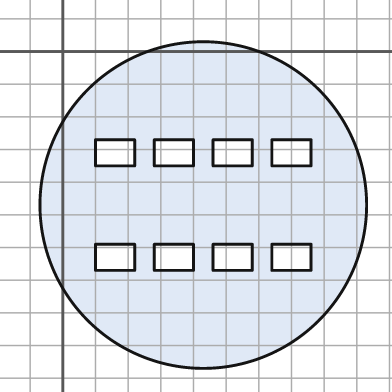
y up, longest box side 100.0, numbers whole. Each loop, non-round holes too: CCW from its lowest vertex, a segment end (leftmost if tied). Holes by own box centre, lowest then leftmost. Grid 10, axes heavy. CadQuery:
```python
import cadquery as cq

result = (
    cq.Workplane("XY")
    .moveTo(43.0, -47.0)
    .circle(50.0)
    .moveTo(10.0, -67.0)
    .lineTo(22.0, -67.0)
    .lineTo(22.0, -59.0)
    .lineTo(10.0, -59.0)
    .close()
    .moveTo(28.0, -67.0)
    .lineTo(40.0, -67.0)
    .lineTo(40.0, -59.0)
    .lineTo(28.0, -59.0)
    .close()
    .moveTo(46.0, -67.0)
    .lineTo(58.0, -67.0)
    .lineTo(58.0, -59.0)
    .lineTo(46.0, -59.0)
    .close()
    .moveTo(64.0, -67.0)
    .lineTo(76.0, -67.0)
    .lineTo(76.0, -59.0)
    .lineTo(64.0, -59.0)
    .close()
    .moveTo(10.0, -35.0)
    .lineTo(22.0, -35.0)
    .lineTo(22.0, -27.0)
    .lineTo(10.0, -27.0)
    .close()
    .moveTo(28.0, -35.0)
    .lineTo(40.0, -35.0)
    .lineTo(40.0, -27.0)
    .lineTo(28.0, -27.0)
    .close()
    .moveTo(46.0, -35.0)
    .lineTo(58.0, -35.0)
    .lineTo(58.0, -27.0)
    .lineTo(46.0, -27.0)
    .close()
    .moveTo(64.0, -35.0)
    .lineTo(76.0, -35.0)
    .lineTo(76.0, -27.0)
    .lineTo(64.0, -27.0)
    .close()
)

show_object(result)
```